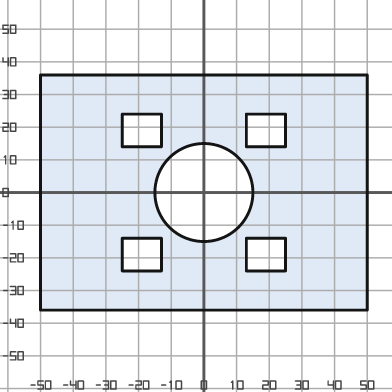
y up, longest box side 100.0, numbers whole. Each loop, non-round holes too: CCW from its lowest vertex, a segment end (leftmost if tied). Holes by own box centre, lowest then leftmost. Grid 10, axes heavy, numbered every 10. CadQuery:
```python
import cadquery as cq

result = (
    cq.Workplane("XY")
    .moveTo(-50.0, -36.0)
    .lineTo(50.0, -36.0)
    .lineTo(50.0, 36.0)
    .lineTo(-50.0, 36.0)
    .close()
    .moveTo(-25.0, -24.0)
    .lineTo(-13.0, -24.0)
    .lineTo(-13.0, -14.0)
    .lineTo(-25.0, -14.0)
    .close()
    .moveTo(13.0, -24.0)
    .lineTo(25.0, -24.0)
    .lineTo(25.0, -14.0)
    .lineTo(13.0, -14.0)
    .close()
    .moveTo(0.0, 0.0)
    .circle(15.0)
    .moveTo(-25.0, 14.0)
    .lineTo(-13.0, 14.0)
    .lineTo(-13.0, 24.0)
    .lineTo(-25.0, 24.0)
    .close()
    .moveTo(13.0, 14.0)
    .lineTo(25.0, 14.0)
    .lineTo(25.0, 24.0)
    .lineTo(13.0, 24.0)
    .close()
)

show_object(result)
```